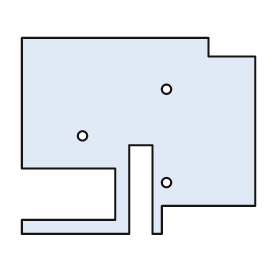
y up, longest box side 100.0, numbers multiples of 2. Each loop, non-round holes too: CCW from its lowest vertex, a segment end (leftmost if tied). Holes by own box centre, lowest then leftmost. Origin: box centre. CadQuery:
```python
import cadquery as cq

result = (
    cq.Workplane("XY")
    .moveTo(-50.0, -42.0)
    .lineTo(-4.0, -42.0)
    .lineTo(-4.0, -4.0)
    .lineTo(6.0, -4.0)
    .lineTo(6.0, -42.0)
    .lineTo(10.0, -42.0)
    .lineTo(10.0, -30.0)
    .lineTo(50.0, -30.0)
    .lineTo(50.0, 34.0)
    .lineTo(30.0, 34.0)
    .lineTo(30.0, 42.0)
    .lineTo(-50.0, 42.0)
    .lineTo(-50.0, -14.0)
    .lineTo(-10.0, -14.0)
    .lineTo(-10.0, -36.0)
    .lineTo(-50.0, -36.0)
    .close()
    .moveTo(12.0, -20.0)
    .circle(2.0)
    .moveTo(-24.0, 0.0)
    .circle(2.0)
    .moveTo(12.0, 20.0)
    .circle(2.0)
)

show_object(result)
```